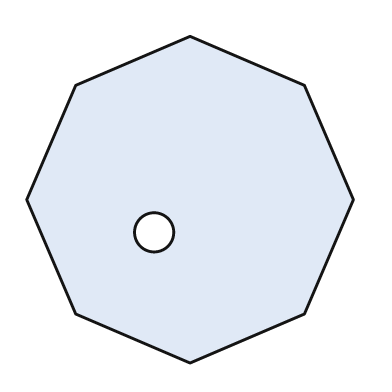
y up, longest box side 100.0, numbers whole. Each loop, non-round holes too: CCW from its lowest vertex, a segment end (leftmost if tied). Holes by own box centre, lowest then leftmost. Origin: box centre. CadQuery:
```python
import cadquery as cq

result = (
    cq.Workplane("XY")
    .moveTo(0.0, -50.0)
    .lineTo(35.0, -35.0)
    .lineTo(50.0, 0.0)
    .lineTo(35.0, 35.0)
    .lineTo(0.0, 50.0)
    .lineTo(-35.0, 35.0)
    .lineTo(-50.0, 0.0)
    .lineTo(-35.0, -35.0)
    .close()
    .moveTo(-11.0, -10.0)
    .circle(6.0)
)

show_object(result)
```